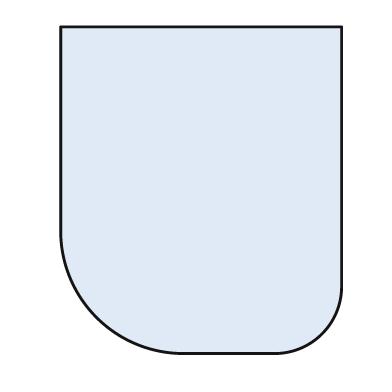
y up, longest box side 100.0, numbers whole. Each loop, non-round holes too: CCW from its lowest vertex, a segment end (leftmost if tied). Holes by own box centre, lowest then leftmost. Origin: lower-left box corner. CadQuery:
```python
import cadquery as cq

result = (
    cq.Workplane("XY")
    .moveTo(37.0, 0.0)
    .lineTo(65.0, 0.0)
    .threePointArc((80.0, 6.0), (86.0, 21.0))
    .lineTo(86.0, 100.0)
    .lineTo(0.0, 100.0)
    .lineTo(0.0, 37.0)
    .threePointArc((11.0, 11.0), (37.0, 0.0))
    .close()
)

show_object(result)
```